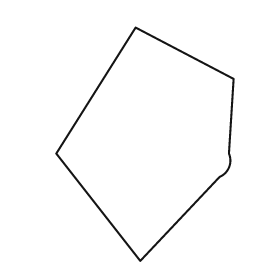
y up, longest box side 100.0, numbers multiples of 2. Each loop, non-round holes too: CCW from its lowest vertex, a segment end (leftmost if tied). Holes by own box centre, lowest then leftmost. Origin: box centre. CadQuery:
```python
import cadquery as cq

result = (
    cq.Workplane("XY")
    .moveTo(-2.0, -50.0)
    .lineTo(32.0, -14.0)
    .threePointArc((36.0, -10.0), (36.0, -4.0))
    .lineTo(38.0, 28.0)
    .lineTo(-4.0, 50.0)
    .lineTo(-38.0, -4.0)
    .close()
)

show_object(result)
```